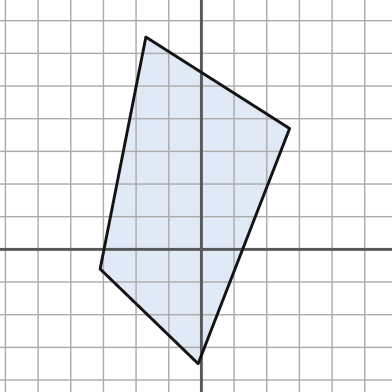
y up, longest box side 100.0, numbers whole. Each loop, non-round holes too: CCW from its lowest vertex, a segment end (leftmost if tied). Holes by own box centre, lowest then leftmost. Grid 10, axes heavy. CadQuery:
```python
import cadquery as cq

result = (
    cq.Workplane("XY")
    .moveTo(-1.0, -35.0)
    .lineTo(27.0, 37.0)
    .lineTo(-17.0, 65.0)
    .lineTo(-31.0, -6.0)
    .close()
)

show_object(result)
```